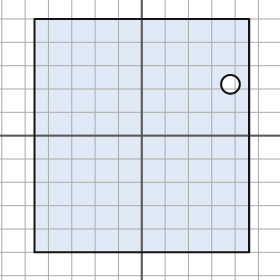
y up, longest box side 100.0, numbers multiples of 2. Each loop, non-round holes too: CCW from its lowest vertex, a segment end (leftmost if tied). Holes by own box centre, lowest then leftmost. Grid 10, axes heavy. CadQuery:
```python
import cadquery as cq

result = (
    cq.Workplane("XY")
    .moveTo(-46.0, -50.0)
    .lineTo(46.0, -50.0)
    .lineTo(46.0, 50.0)
    .lineTo(-46.0, 50.0)
    .close()
    .moveTo(38.0, 22.0)
    .circle(4.0)
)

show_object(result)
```